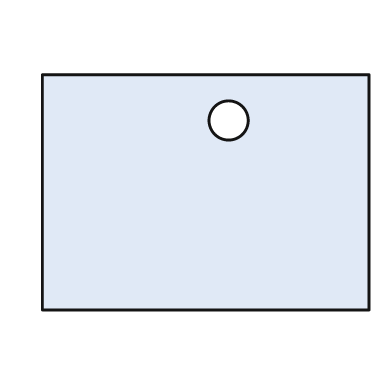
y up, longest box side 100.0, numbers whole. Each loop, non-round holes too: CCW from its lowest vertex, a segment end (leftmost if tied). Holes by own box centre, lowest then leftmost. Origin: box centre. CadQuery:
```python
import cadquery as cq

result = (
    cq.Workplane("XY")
    .moveTo(-50.0, -36.0)
    .lineTo(50.0, -36.0)
    .lineTo(50.0, 36.0)
    .lineTo(-50.0, 36.0)
    .close()
    .moveTo(7.0, 22.0)
    .circle(6.0)
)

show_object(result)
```